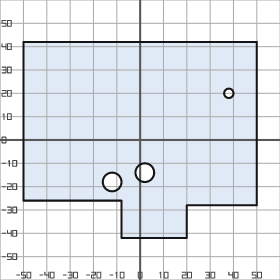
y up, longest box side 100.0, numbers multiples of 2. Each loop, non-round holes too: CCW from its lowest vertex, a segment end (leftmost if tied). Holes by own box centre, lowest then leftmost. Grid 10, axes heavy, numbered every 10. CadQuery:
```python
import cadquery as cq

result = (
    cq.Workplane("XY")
    .moveTo(-8.0, -42.0)
    .lineTo(20.0, -42.0)
    .lineTo(20.0, -28.0)
    .lineTo(50.0, -28.0)
    .lineTo(50.0, 42.0)
    .lineTo(-50.0, 42.0)
    .lineTo(-50.0, -26.0)
    .lineTo(-8.0, -26.0)
    .close()
    .moveTo(-12.0, -18.0)
    .circle(4.0)
    .moveTo(2.0, -14.0)
    .circle(4.0)
    .moveTo(38.0, 20.0)
    .circle(2.0)
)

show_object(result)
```